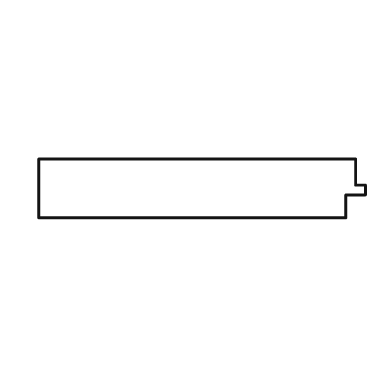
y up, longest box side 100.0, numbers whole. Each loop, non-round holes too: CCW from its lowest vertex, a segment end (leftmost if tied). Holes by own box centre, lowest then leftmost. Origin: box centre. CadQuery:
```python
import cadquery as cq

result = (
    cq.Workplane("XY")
    .moveTo(-50.0, -9.0)
    .lineTo(44.0, -9.0)
    .lineTo(44.0, -2.0)
    .lineTo(50.0, -2.0)
    .lineTo(50.0, 1.0)
    .lineTo(47.0, 1.0)
    .lineTo(47.0, 9.0)
    .lineTo(-50.0, 9.0)
    .close()
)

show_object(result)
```